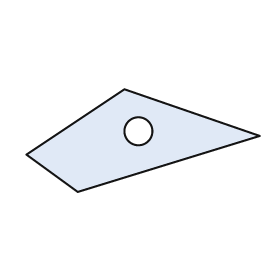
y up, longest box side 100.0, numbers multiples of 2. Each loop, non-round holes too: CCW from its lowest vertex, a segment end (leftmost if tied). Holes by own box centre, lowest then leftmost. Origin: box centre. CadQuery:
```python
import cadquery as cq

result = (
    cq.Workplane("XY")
    .moveTo(-28.0, -22.0)
    .lineTo(50.0, 2.0)
    .lineTo(-8.0, 22.0)
    .lineTo(-50.0, -6.0)
    .close()
    .moveTo(-2.0, 4.0)
    .circle(6.0)
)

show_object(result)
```